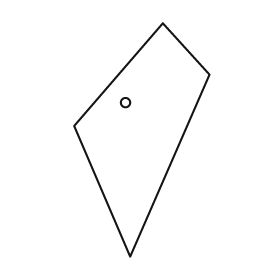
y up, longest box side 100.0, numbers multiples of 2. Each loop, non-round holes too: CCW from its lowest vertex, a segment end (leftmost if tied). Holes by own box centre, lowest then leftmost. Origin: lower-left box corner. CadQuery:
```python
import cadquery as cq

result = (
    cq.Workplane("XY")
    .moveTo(24.0, 0.0)
    .lineTo(58.0, 78.0)
    .lineTo(38.0, 100.0)
    .lineTo(0.0, 56.0)
    .close()
    .moveTo(22.0, 66.0)
    .circle(2.0)
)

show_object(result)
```